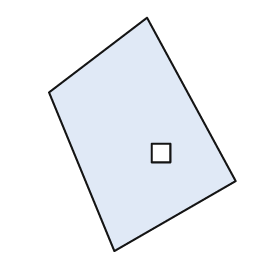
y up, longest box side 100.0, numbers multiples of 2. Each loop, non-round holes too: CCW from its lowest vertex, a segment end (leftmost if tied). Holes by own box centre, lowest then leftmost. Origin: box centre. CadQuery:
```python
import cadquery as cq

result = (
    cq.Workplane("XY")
    .moveTo(-12.0, -50.0)
    .lineTo(40.0, -20.0)
    .lineTo(2.0, 50.0)
    .lineTo(-40.0, 18.0)
    .close()
    .moveTo(4.0, -12.0)
    .lineTo(12.0, -12.0)
    .lineTo(12.0, -4.0)
    .lineTo(4.0, -4.0)
    .close()
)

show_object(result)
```